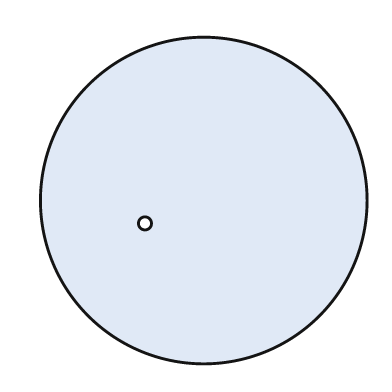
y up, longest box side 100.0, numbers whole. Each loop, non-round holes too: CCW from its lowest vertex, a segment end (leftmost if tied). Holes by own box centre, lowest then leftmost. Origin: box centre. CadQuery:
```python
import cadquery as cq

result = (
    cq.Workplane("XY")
    .moveTo(0.0, 0.0)
    .circle(50.0)
    .moveTo(-18.0, -7.0)
    .circle(2.0)
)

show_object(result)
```